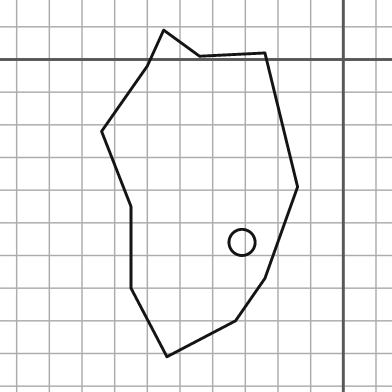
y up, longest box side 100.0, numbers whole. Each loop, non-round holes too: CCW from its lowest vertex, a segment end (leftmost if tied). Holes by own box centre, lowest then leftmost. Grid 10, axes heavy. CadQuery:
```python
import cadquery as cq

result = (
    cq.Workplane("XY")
    .moveTo(-54.0, -91.0)
    .lineTo(-33.0, -80.0)
    .lineTo(-24.0, -67.0)
    .lineTo(-14.0, -39.0)
    .lineTo(-24.0, 2.0)
    .lineTo(-44.0, 1.0)
    .lineTo(-55.0, 9.0)
    .lineTo(-60.0, -2.0)
    .lineTo(-74.0, -22.0)
    .lineTo(-65.0, -45.0)
    .lineTo(-65.0, -70.0)
    .close()
    .moveTo(-31.0, -56.0)
    .circle(4.0)
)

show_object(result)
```